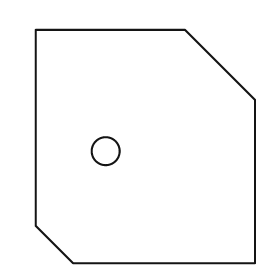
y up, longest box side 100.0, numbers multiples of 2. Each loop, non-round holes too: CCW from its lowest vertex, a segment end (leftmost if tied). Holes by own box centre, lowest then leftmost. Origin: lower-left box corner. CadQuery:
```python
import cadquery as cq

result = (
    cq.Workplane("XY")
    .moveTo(16.0, 0.0)
    .lineTo(94.0, 0.0)
    .lineTo(94.0, 70.0)
    .lineTo(64.0, 100.0)
    .lineTo(0.0, 100.0)
    .lineTo(0.0, 16.0)
    .close()
    .moveTo(30.0, 48.0)
    .circle(6.0)
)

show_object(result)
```